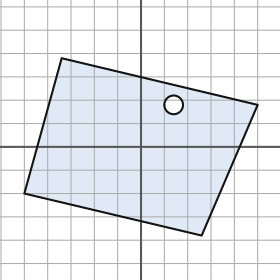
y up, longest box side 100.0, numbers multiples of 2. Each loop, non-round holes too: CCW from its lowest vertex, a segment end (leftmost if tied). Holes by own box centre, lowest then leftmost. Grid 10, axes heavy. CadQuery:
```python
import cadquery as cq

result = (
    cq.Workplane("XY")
    .moveTo(26.0, -38.0)
    .lineTo(50.0, 18.0)
    .lineTo(-34.0, 38.0)
    .lineTo(-50.0, -20.0)
    .close()
    .moveTo(14.0, 18.0)
    .circle(4.0)
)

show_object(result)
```